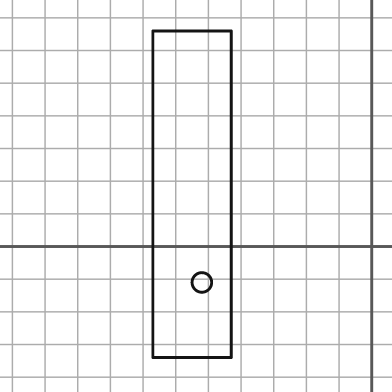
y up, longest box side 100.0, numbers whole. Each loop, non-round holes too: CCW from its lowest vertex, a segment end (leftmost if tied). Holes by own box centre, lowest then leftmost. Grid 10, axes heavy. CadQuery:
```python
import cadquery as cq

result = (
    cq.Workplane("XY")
    .moveTo(-67.0, -34.0)
    .lineTo(-43.0, -34.0)
    .lineTo(-43.0, 66.0)
    .lineTo(-67.0, 66.0)
    .close()
    .moveTo(-52.0, -11.0)
    .circle(3.0)
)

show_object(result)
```